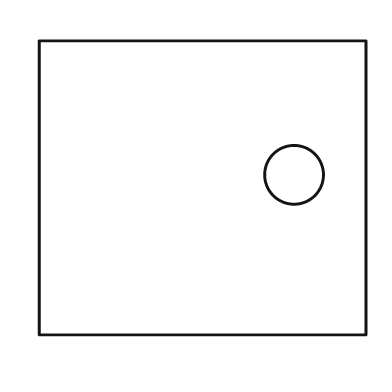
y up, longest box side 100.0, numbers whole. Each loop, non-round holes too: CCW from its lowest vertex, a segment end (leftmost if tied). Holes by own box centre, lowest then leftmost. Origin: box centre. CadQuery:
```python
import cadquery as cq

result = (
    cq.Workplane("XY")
    .moveTo(-50.0, -45.0)
    .lineTo(50.0, -45.0)
    .lineTo(50.0, 45.0)
    .lineTo(-50.0, 45.0)
    .close()
    .moveTo(28.0, 4.0)
    .circle(9.0)
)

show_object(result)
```